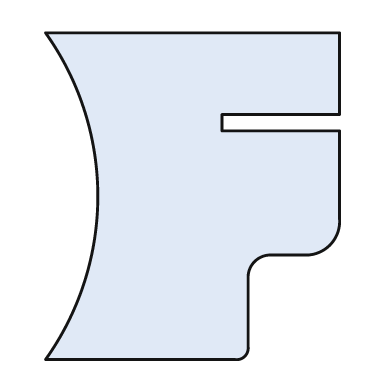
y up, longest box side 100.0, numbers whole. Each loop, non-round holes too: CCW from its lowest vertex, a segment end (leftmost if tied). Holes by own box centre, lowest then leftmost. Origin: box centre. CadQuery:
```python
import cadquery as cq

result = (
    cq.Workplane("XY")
    .moveTo(-45.0, -50.0)
    .lineTo(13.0, -50.0)
    .threePointArc((16.0, -49.0), (17.0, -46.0))
    .lineTo(17.0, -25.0)
    .threePointArc((19.0, -20.0), (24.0, -18.0))
    .lineTo(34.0, -18.0)
    .threePointArc((42.0, -15.0), (45.0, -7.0))
    .lineTo(45.0, 20.0)
    .lineTo(9.0, 20.0)
    .lineTo(9.0, 25.0)
    .lineTo(45.0, 25.0)
    .lineTo(45.0, 50.0)
    .lineTo(-45.0, 50.0)
    .threePointArc((-29.0, 0.0), (-45.0, -50.0))
    .close()
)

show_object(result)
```